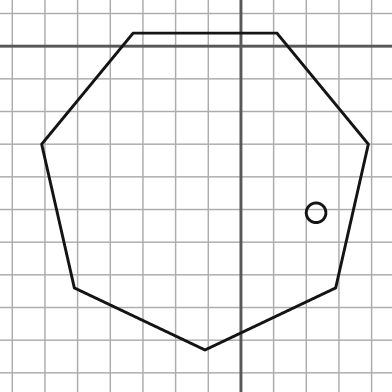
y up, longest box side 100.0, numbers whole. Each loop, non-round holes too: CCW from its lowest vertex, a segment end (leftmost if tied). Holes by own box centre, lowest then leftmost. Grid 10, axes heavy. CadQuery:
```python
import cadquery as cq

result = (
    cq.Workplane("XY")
    .moveTo(-11.0, -93.0)
    .lineTo(29.0, -74.0)
    .lineTo(39.0, -30.0)
    .lineTo(11.0, 4.0)
    .lineTo(-33.0, 4.0)
    .lineTo(-61.0, -30.0)
    .lineTo(-51.0, -74.0)
    .close()
    .moveTo(23.0, -51.0)
    .circle(3.0)
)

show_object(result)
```